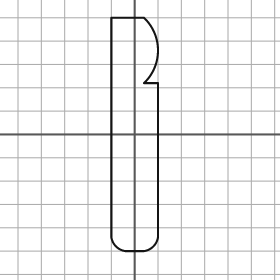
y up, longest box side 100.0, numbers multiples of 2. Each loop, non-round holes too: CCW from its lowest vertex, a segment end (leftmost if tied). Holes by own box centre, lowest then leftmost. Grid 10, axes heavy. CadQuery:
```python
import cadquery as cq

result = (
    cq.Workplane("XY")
    .moveTo(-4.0, -50.0)
    .lineTo(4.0, -50.0)
    .threePointArc((8.0, -48.0), (10.0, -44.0))
    .lineTo(10.0, 22.0)
    .lineTo(4.0, 22.0)
    .threePointArc((10.0, 36.0), (4.0, 50.0))
    .lineTo(-10.0, 50.0)
    .lineTo(-10.0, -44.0)
    .threePointArc((-8.0, -48.0), (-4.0, -50.0))
    .close()
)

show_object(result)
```